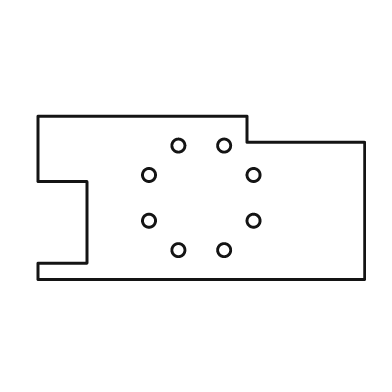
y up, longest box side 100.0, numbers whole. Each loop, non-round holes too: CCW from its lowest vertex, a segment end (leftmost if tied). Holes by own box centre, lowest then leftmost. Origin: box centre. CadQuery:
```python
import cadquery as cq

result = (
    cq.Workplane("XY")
    .moveTo(-50.0, -25.0)
    .lineTo(50.0, -25.0)
    .lineTo(50.0, 17.0)
    .lineTo(14.0, 17.0)
    .lineTo(14.0, 25.0)
    .lineTo(-50.0, 25.0)
    .lineTo(-50.0, 5.0)
    .lineTo(-35.0, 5.0)
    .lineTo(-35.0, -20.0)
    .lineTo(-50.0, -20.0)
    .close()
    .moveTo(-7.0, -16.0)
    .circle(2.0)
    .moveTo(7.0, -16.0)
    .circle(2.0)
    .moveTo(-16.0, -7.0)
    .circle(2.0)
    .moveTo(16.0, -7.0)
    .circle(2.0)
    .moveTo(-16.0, 7.0)
    .circle(2.0)
    .moveTo(16.0, 7.0)
    .circle(2.0)
    .moveTo(-7.0, 16.0)
    .circle(2.0)
    .moveTo(7.0, 16.0)
    .circle(2.0)
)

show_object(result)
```